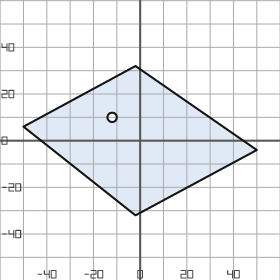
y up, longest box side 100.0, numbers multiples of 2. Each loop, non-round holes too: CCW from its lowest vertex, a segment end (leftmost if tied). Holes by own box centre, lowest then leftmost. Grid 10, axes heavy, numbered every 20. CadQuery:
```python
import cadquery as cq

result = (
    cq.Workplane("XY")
    .moveTo(-2.0, -32.0)
    .lineTo(50.0, -4.0)
    .lineTo(-2.0, 32.0)
    .lineTo(-50.0, 6.0)
    .close()
    .moveTo(-12.0, 10.0)
    .circle(2.0)
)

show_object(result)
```